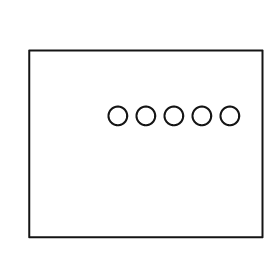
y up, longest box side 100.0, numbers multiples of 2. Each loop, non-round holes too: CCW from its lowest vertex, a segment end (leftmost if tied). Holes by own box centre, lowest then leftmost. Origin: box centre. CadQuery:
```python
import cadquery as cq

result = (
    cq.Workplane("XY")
    .moveTo(-50.0, -40.0)
    .lineTo(50.0, -40.0)
    .lineTo(50.0, 40.0)
    .lineTo(-50.0, 40.0)
    .close()
    .moveTo(-12.0, 12.0)
    .circle(4.0)
    .moveTo(0.0, 12.0)
    .circle(4.0)
    .moveTo(12.0, 12.0)
    .circle(4.0)
    .moveTo(24.0, 12.0)
    .circle(4.0)
    .moveTo(36.0, 12.0)
    .circle(4.0)
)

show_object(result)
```